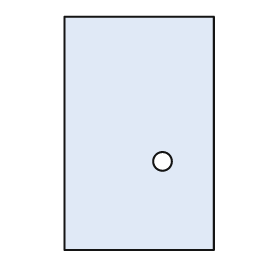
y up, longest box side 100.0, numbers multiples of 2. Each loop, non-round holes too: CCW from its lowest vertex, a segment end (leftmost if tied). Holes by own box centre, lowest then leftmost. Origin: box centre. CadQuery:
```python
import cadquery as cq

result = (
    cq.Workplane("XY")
    .moveTo(-32.0, -50.0)
    .lineTo(32.0, -50.0)
    .lineTo(32.0, 50.0)
    .lineTo(-32.0, 50.0)
    .close()
    .moveTo(10.0, -12.0)
    .circle(4.0)
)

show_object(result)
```